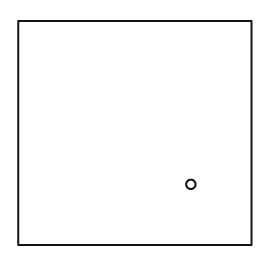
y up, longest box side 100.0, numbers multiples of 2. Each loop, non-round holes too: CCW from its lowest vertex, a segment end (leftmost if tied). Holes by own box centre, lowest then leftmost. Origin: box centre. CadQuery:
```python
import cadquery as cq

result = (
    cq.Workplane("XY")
    .moveTo(-50.0, -48.0)
    .lineTo(50.0, -48.0)
    .lineTo(50.0, 48.0)
    .lineTo(-50.0, 48.0)
    .close()
    .moveTo(24.0, -22.0)
    .circle(2.0)
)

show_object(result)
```